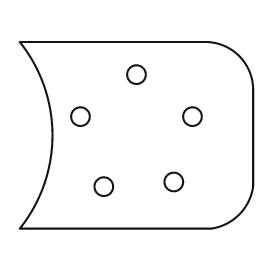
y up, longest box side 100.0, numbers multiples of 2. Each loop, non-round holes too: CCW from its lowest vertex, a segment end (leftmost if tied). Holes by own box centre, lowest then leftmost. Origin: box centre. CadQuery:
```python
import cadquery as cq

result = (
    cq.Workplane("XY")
    .moveTo(-50.0, -40.0)
    .lineTo(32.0, -40.0)
    .threePointArc((44.0, -34.0), (50.0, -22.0))
    .lineTo(50.0, 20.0)
    .threePointArc((44.0, 34.0), (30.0, 40.0))
    .lineTo(-50.0, 40.0)
    .threePointArc((-36.0, 0.0), (-50.0, -40.0))
    .close()
    .moveTo(-14.0, -22.0)
    .circle(4.0)
    .moveTo(16.0, -20.0)
    .circle(4.0)
    .moveTo(-24.0, 8.0)
    .circle(4.0)
    .moveTo(24.0, 8.0)
    .circle(4.0)
    .moveTo(0.0, 26.0)
    .circle(4.0)
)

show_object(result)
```